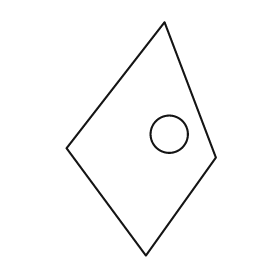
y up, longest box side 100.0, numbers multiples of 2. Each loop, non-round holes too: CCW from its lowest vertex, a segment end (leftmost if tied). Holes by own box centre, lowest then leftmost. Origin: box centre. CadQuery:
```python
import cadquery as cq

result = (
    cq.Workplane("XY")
    .moveTo(2.0, -50.0)
    .lineTo(32.0, -8.0)
    .lineTo(10.0, 50.0)
    .lineTo(-32.0, -4.0)
    .close()
    .moveTo(12.0, 2.0)
    .circle(8.0)
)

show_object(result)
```